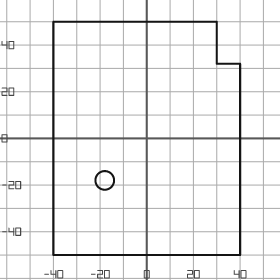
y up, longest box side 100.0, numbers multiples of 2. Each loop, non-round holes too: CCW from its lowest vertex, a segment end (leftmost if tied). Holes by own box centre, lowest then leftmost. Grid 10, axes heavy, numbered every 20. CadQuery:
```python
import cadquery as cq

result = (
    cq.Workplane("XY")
    .moveTo(-40.0, -50.0)
    .lineTo(40.0, -50.0)
    .lineTo(40.0, 32.0)
    .lineTo(30.0, 32.0)
    .lineTo(30.0, 50.0)
    .lineTo(-40.0, 50.0)
    .close()
    .moveTo(-18.0, -18.0)
    .circle(4.0)
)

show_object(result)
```